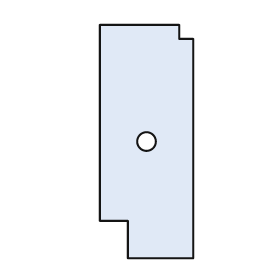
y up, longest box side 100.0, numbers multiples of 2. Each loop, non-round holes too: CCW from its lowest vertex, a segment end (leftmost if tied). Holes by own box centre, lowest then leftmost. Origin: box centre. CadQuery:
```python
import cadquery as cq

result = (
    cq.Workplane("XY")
    .moveTo(-8.0, -50.0)
    .lineTo(20.0, -50.0)
    .lineTo(20.0, 44.0)
    .lineTo(14.0, 44.0)
    .lineTo(14.0, 50.0)
    .lineTo(-20.0, 50.0)
    .lineTo(-20.0, -34.0)
    .lineTo(-8.0, -34.0)
    .close()
    .moveTo(0.0, 0.0)
    .circle(4.0)
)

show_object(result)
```